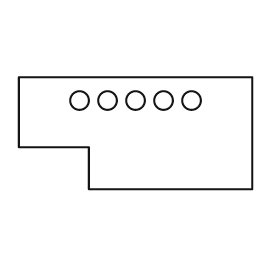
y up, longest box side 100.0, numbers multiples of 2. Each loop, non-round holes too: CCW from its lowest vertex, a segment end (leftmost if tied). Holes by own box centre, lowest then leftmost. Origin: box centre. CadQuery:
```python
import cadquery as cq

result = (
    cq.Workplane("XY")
    .moveTo(-20.0, -24.0)
    .lineTo(50.0, -24.0)
    .lineTo(50.0, 24.0)
    .lineTo(-50.0, 24.0)
    .lineTo(-50.0, -6.0)
    .lineTo(-20.0, -6.0)
    .close()
    .moveTo(-24.0, 14.0)
    .circle(4.0)
    .moveTo(-12.0, 14.0)
    .circle(4.0)
    .moveTo(0.0, 14.0)
    .circle(4.0)
    .moveTo(12.0, 14.0)
    .circle(4.0)
    .moveTo(24.0, 14.0)
    .circle(4.0)
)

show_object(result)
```